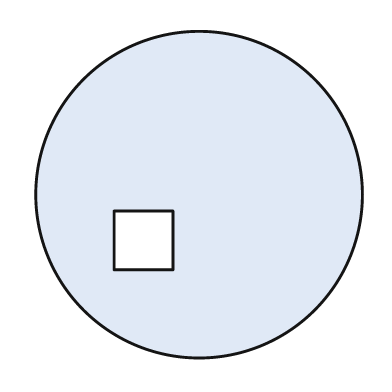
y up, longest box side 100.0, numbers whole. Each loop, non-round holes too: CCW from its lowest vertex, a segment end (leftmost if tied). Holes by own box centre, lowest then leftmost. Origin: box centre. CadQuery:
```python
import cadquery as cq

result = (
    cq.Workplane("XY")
    .moveTo(0.0, 0.0)
    .circle(50.0)
    .moveTo(-26.0, -23.0)
    .lineTo(-8.0, -23.0)
    .lineTo(-8.0, -5.0)
    .lineTo(-26.0, -5.0)
    .close()
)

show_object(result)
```